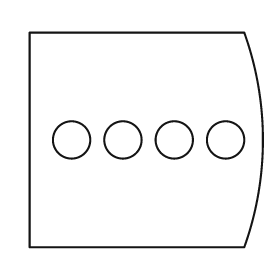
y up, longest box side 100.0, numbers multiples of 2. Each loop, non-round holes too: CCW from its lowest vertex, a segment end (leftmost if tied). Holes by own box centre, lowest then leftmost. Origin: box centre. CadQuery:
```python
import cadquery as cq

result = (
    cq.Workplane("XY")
    .moveTo(-50.0, -46.0)
    .lineTo(42.0, -46.0)
    .threePointArc((50.0, 0.0), (42.0, 46.0))
    .lineTo(-50.0, 46.0)
    .close()
    .moveTo(-32.0, 0.0)
    .circle(8.0)
    .moveTo(-10.0, 0.0)
    .circle(8.0)
    .moveTo(12.0, 0.0)
    .circle(8.0)
    .moveTo(34.0, 0.0)
    .circle(8.0)
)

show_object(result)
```